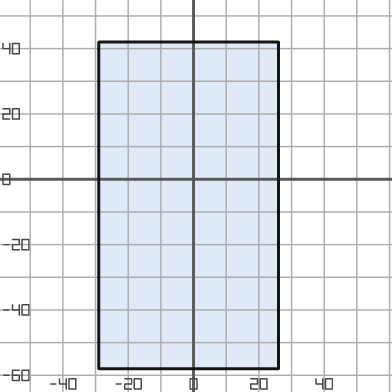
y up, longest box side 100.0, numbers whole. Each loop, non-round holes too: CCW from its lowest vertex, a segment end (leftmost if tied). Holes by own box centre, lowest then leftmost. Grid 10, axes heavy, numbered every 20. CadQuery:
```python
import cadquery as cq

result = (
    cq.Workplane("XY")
    .moveTo(-29.0, -58.0)
    .lineTo(26.0, -58.0)
    .lineTo(26.0, 42.0)
    .lineTo(-29.0, 42.0)
    .close()
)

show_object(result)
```